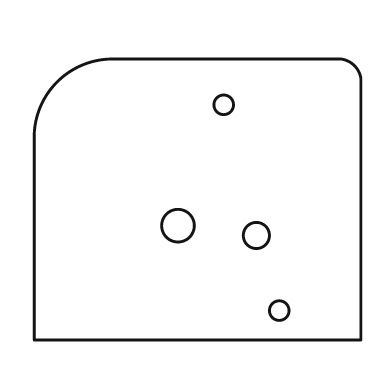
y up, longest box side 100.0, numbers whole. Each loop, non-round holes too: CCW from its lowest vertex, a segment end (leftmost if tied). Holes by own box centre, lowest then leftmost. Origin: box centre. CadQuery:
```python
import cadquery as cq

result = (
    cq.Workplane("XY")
    .moveTo(-50.0, -43.0)
    .lineTo(50.0, -43.0)
    .lineTo(50.0, 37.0)
    .threePointArc((48.0, 41.0), (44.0, 43.0))
    .lineTo(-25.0, 43.0)
    .threePointArc((-43.0, 36.0), (-50.0, 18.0))
    .close()
    .moveTo(25.0, -34.0)
    .circle(3.0)
    .moveTo(18.0, -11.0)
    .circle(4.0)
    .moveTo(-6.0, -8.0)
    .circle(5.0)
    .moveTo(8.0, 29.0)
    .circle(3.0)
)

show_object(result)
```